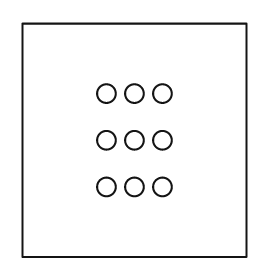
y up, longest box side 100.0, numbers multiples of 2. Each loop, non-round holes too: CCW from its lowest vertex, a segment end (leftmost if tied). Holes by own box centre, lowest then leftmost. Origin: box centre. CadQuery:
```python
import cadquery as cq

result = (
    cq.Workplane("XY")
    .moveTo(-48.0, -50.0)
    .lineTo(48.0, -50.0)
    .lineTo(48.0, 50.0)
    .lineTo(-48.0, 50.0)
    .close()
    .moveTo(-12.0, -20.0)
    .circle(4.0)
    .moveTo(0.0, -20.0)
    .circle(4.0)
    .moveTo(12.0, -20.0)
    .circle(4.0)
    .moveTo(-12.0, 0.0)
    .circle(4.0)
    .moveTo(0.0, 0.0)
    .circle(4.0)
    .moveTo(12.0, 0.0)
    .circle(4.0)
    .moveTo(-12.0, 20.0)
    .circle(4.0)
    .moveTo(0.0, 20.0)
    .circle(4.0)
    .moveTo(12.0, 20.0)
    .circle(4.0)
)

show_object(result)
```